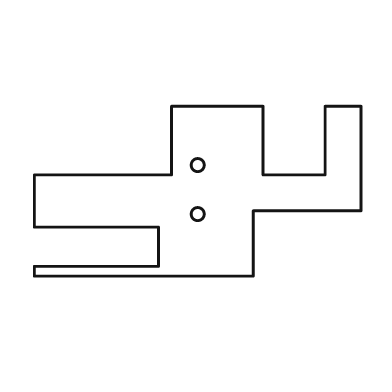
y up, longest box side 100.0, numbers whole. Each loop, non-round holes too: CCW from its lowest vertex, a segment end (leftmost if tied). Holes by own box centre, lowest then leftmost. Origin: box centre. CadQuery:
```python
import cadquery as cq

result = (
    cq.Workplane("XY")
    .moveTo(-50.0, -26.0)
    .lineTo(17.0, -26.0)
    .lineTo(17.0, -6.0)
    .lineTo(50.0, -6.0)
    .lineTo(50.0, 26.0)
    .lineTo(39.0, 26.0)
    .lineTo(39.0, 5.0)
    .lineTo(20.0, 5.0)
    .lineTo(20.0, 26.0)
    .lineTo(-8.0, 26.0)
    .lineTo(-8.0, 5.0)
    .lineTo(-50.0, 5.0)
    .lineTo(-50.0, -11.0)
    .lineTo(-12.0, -11.0)
    .lineTo(-12.0, -23.0)
    .lineTo(-50.0, -23.0)
    .close()
    .moveTo(0.0, -7.0)
    .circle(2.0)
    .moveTo(0.0, 8.0)
    .circle(2.0)
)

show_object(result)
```